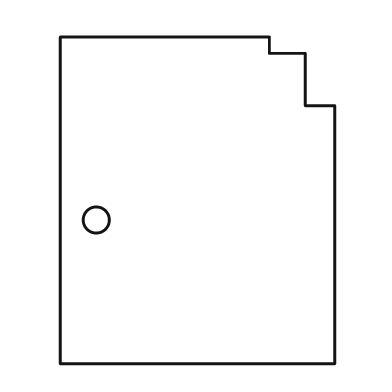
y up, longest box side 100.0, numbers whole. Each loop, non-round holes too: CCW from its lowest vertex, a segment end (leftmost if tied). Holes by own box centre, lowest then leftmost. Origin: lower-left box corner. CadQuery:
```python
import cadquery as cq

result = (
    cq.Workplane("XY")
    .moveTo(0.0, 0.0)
    .lineTo(84.0, 0.0)
    .lineTo(84.0, 79.0)
    .lineTo(75.0, 79.0)
    .lineTo(75.0, 95.0)
    .lineTo(64.0, 95.0)
    .lineTo(64.0, 100.0)
    .lineTo(0.0, 100.0)
    .close()
    .moveTo(11.0, 44.0)
    .circle(4.0)
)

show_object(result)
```